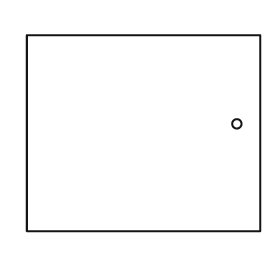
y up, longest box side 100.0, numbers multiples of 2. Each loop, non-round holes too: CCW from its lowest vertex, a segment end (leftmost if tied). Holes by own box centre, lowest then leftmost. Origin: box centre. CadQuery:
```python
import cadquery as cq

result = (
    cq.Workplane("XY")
    .moveTo(-50.0, -42.0)
    .lineTo(50.0, -42.0)
    .lineTo(50.0, 42.0)
    .lineTo(-50.0, 42.0)
    .close()
    .moveTo(40.0, 4.0)
    .circle(2.0)
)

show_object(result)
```